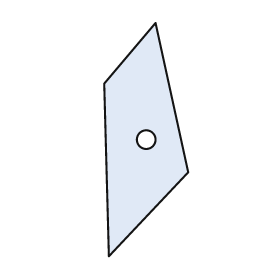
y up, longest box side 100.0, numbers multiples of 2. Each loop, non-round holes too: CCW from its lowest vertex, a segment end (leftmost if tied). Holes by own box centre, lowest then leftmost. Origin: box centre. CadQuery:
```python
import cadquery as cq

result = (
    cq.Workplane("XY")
    .moveTo(-16.0, -50.0)
    .lineTo(18.0, -14.0)
    .lineTo(4.0, 50.0)
    .lineTo(-18.0, 24.0)
    .close()
    .moveTo(0.0, 0.0)
    .circle(4.0)
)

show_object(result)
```